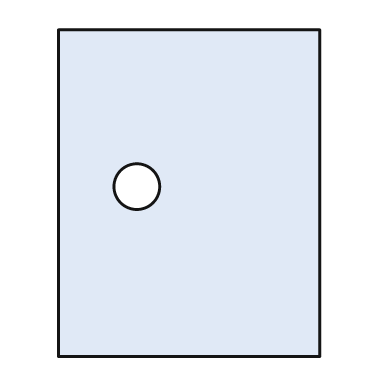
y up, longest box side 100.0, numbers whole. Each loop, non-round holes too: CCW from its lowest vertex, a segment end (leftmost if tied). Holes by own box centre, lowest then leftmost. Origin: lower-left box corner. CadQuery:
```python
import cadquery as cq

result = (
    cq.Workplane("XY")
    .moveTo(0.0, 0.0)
    .lineTo(80.0, 0.0)
    .lineTo(80.0, 100.0)
    .lineTo(0.0, 100.0)
    .close()
    .moveTo(24.0, 52.0)
    .circle(7.0)
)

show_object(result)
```